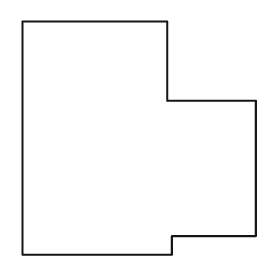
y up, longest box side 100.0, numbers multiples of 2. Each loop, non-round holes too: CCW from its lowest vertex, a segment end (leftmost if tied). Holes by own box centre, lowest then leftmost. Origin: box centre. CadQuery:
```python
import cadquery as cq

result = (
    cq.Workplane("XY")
    .moveTo(-50.0, -50.0)
    .lineTo(14.0, -50.0)
    .lineTo(14.0, -42.0)
    .lineTo(50.0, -42.0)
    .lineTo(50.0, 16.0)
    .lineTo(12.0, 16.0)
    .lineTo(12.0, 50.0)
    .lineTo(-50.0, 50.0)
    .close()
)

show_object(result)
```